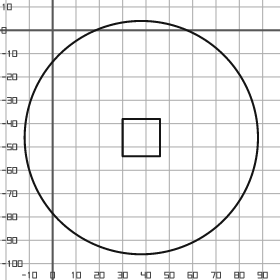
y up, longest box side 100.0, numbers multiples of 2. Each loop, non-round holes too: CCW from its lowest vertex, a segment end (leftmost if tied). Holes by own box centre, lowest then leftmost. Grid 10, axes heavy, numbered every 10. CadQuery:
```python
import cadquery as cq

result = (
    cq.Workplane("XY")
    .moveTo(38.0, -46.0)
    .circle(50.0)
    .moveTo(30.0, -54.0)
    .lineTo(46.0, -54.0)
    .lineTo(46.0, -38.0)
    .lineTo(30.0, -38.0)
    .close()
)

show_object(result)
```